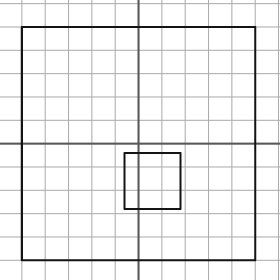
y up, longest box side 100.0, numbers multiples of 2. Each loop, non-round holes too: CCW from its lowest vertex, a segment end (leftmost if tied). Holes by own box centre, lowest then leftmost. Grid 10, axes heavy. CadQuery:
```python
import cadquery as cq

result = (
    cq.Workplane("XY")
    .moveTo(-50.0, -50.0)
    .lineTo(50.0, -50.0)
    .lineTo(50.0, 50.0)
    .lineTo(-50.0, 50.0)
    .close()
    .moveTo(-6.0, -28.0)
    .lineTo(18.0, -28.0)
    .lineTo(18.0, -4.0)
    .lineTo(-6.0, -4.0)
    .close()
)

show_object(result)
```